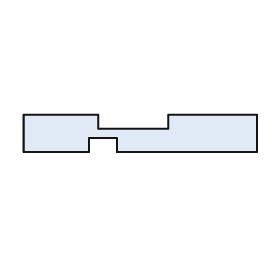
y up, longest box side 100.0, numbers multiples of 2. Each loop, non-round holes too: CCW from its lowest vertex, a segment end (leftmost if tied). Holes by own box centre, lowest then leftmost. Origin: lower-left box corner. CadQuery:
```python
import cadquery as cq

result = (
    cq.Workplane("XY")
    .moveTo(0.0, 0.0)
    .lineTo(28.0, 0.0)
    .lineTo(28.0, 6.0)
    .lineTo(40.0, 6.0)
    .lineTo(40.0, 0.0)
    .lineTo(100.0, 0.0)
    .lineTo(100.0, 16.0)
    .lineTo(62.0, 16.0)
    .lineTo(62.0, 10.0)
    .lineTo(32.0, 10.0)
    .lineTo(32.0, 16.0)
    .lineTo(0.0, 16.0)
    .close()
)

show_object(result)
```